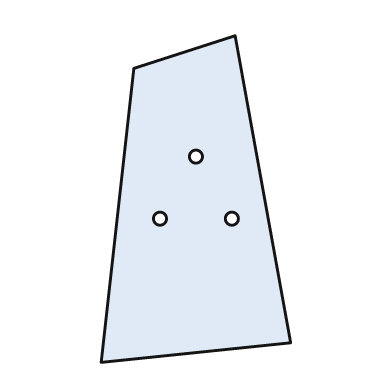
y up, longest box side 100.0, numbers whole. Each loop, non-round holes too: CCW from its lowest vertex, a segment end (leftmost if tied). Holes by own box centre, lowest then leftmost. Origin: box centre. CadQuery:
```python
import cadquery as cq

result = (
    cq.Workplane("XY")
    .moveTo(-29.0, -50.0)
    .lineTo(29.0, -44.0)
    .lineTo(12.0, 50.0)
    .lineTo(-19.0, 40.0)
    .close()
    .moveTo(-11.0, -6.0)
    .circle(2.0)
    .moveTo(11.0, -6.0)
    .circle(2.0)
    .moveTo(0.0, 13.0)
    .circle(2.0)
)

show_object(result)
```